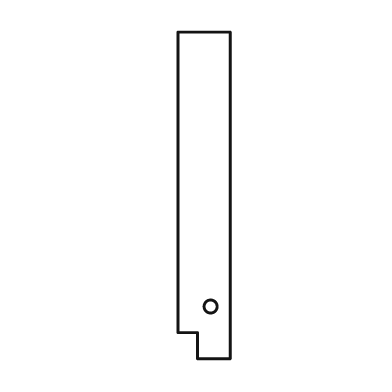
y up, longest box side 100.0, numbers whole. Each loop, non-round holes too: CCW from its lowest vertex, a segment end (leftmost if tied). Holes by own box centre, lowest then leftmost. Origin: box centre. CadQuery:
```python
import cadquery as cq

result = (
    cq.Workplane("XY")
    .moveTo(-2.0, -50.0)
    .lineTo(8.0, -50.0)
    .lineTo(8.0, 50.0)
    .lineTo(-8.0, 50.0)
    .lineTo(-8.0, -42.0)
    .lineTo(-2.0, -42.0)
    .close()
    .moveTo(2.0, -34.0)
    .circle(2.0)
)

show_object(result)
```